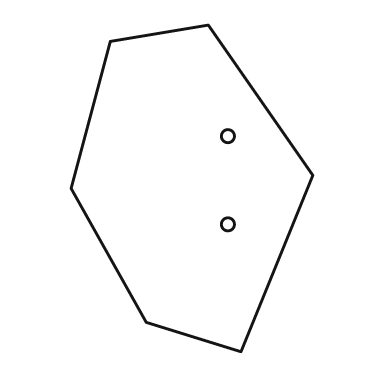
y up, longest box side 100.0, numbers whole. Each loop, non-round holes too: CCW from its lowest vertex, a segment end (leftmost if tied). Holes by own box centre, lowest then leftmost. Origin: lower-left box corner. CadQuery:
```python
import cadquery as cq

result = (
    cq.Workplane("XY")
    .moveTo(52.0, 0.0)
    .lineTo(74.0, 54.0)
    .lineTo(42.0, 100.0)
    .lineTo(12.0, 95.0)
    .lineTo(0.0, 50.0)
    .lineTo(23.0, 9.0)
    .close()
    .moveTo(48.0, 39.0)
    .circle(2.0)
    .moveTo(48.0, 66.0)
    .circle(2.0)
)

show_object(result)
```